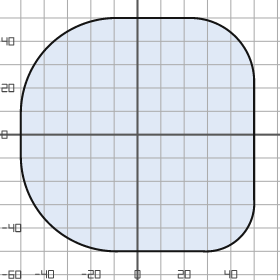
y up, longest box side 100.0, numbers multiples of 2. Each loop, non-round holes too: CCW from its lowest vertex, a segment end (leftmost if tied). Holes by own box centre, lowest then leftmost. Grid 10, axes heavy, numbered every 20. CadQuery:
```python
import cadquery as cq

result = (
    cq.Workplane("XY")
    .moveTo(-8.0, -50.0)
    .lineTo(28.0, -50.0)
    .threePointArc((44.0, -44.0), (50.0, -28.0))
    .lineTo(50.0, 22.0)
    .threePointArc((42.0, 42.0), (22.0, 50.0))
    .lineTo(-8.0, 50.0)
    .threePointArc((-38.0, 38.0), (-50.0, 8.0))
    .lineTo(-50.0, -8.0)
    .threePointArc((-38.0, -38.0), (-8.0, -50.0))
    .close()
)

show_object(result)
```